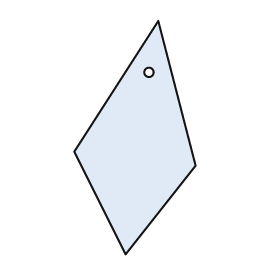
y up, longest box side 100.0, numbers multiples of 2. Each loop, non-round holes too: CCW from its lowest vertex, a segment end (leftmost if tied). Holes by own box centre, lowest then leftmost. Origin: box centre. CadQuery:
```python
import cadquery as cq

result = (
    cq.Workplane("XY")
    .moveTo(-4.0, -50.0)
    .lineTo(26.0, -12.0)
    .lineTo(10.0, 50.0)
    .lineTo(-26.0, -6.0)
    .close()
    .moveTo(6.0, 28.0)
    .circle(2.0)
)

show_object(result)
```